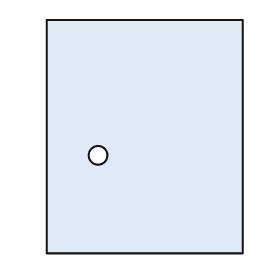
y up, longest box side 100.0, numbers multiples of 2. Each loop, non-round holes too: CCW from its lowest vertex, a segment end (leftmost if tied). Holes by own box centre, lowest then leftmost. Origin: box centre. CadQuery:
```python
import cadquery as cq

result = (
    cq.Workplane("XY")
    .moveTo(-42.0, -50.0)
    .lineTo(42.0, -50.0)
    .lineTo(42.0, 50.0)
    .lineTo(-42.0, 50.0)
    .close()
    .moveTo(-20.0, -8.0)
    .circle(4.0)
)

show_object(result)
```